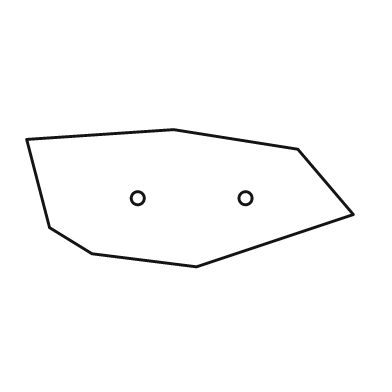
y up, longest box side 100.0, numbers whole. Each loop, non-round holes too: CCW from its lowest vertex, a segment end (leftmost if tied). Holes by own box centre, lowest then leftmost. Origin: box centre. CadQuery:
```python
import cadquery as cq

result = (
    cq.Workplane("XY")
    .moveTo(2.0, -21.0)
    .lineTo(50.0, -5.0)
    .lineTo(33.0, 15.0)
    .lineTo(-5.0, 21.0)
    .lineTo(-50.0, 18.0)
    .lineTo(-43.0, -9.0)
    .lineTo(-30.0, -17.0)
    .close()
    .moveTo(-16.0, 0.0)
    .circle(2.0)
    .moveTo(17.0, 0.0)
    .circle(2.0)
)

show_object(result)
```